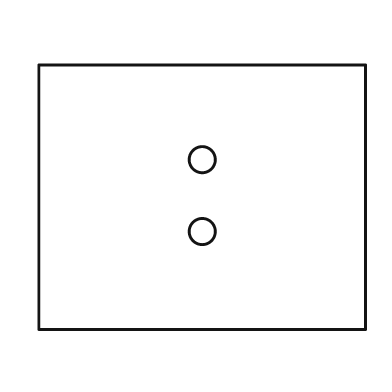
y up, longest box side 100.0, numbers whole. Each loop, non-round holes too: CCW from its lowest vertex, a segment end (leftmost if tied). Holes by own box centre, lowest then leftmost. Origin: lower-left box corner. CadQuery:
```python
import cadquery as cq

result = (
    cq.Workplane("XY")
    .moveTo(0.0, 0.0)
    .lineTo(100.0, 0.0)
    .lineTo(100.0, 81.0)
    .lineTo(0.0, 81.0)
    .close()
    .moveTo(50.0, 30.0)
    .circle(4.0)
    .moveTo(50.0, 52.0)
    .circle(4.0)
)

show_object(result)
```